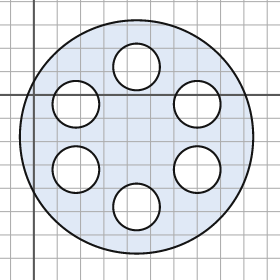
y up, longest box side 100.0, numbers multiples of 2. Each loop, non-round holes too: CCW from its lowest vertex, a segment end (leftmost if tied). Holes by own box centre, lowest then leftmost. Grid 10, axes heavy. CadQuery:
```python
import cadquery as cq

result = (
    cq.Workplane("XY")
    .moveTo(44.0, -18.0)
    .circle(50.0)
    .moveTo(44.0, -48.0)
    .circle(10.0)
    .moveTo(18.0, -32.0)
    .circle(10.0)
    .moveTo(70.0, -32.0)
    .circle(10.0)
    .moveTo(18.0, -4.0)
    .circle(10.0)
    .moveTo(70.0, -4.0)
    .circle(10.0)
    .moveTo(44.0, 12.0)
    .circle(10.0)
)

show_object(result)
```